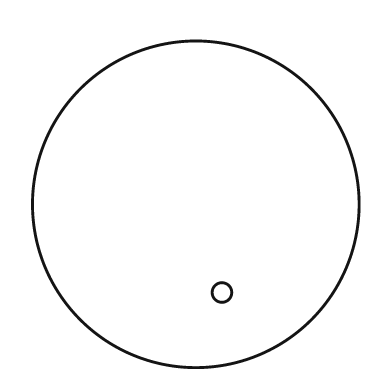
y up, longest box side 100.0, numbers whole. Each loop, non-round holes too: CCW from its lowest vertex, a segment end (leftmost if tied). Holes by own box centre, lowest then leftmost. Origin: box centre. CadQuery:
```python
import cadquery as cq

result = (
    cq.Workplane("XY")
    .moveTo(0.0, 0.0)
    .circle(50.0)
    .moveTo(8.0, -27.0)
    .circle(3.0)
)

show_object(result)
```